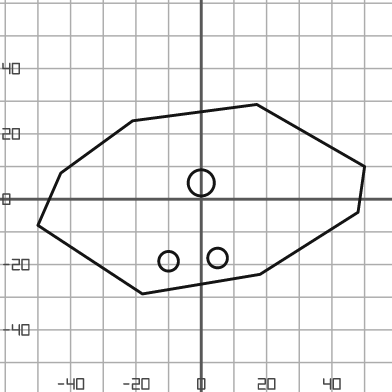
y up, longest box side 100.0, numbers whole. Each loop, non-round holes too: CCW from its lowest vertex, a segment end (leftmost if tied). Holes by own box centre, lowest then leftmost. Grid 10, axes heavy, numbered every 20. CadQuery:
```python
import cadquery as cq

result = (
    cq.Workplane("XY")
    .moveTo(-18.0, -29.0)
    .lineTo(18.0, -23.0)
    .lineTo(48.0, -4.0)
    .lineTo(50.0, 10.0)
    .lineTo(17.0, 29.0)
    .lineTo(-21.0, 24.0)
    .lineTo(-43.0, 8.0)
    .lineTo(-50.0, -8.0)
    .close()
    .moveTo(-10.0, -19.0)
    .circle(3.0)
    .moveTo(5.0, -18.0)
    .circle(3.0)
    .moveTo(0.0, 5.0)
    .circle(4.0)
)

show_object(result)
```